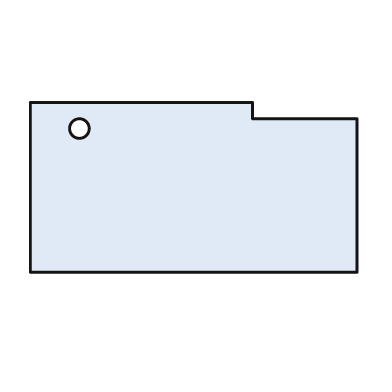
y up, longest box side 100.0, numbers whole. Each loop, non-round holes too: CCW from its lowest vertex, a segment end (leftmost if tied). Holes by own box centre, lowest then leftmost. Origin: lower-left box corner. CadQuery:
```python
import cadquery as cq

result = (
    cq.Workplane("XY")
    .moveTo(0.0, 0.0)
    .lineTo(100.0, 0.0)
    .lineTo(100.0, 47.0)
    .lineTo(68.0, 47.0)
    .lineTo(68.0, 52.0)
    .lineTo(0.0, 52.0)
    .close()
    .moveTo(15.0, 44.0)
    .circle(3.0)
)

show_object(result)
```